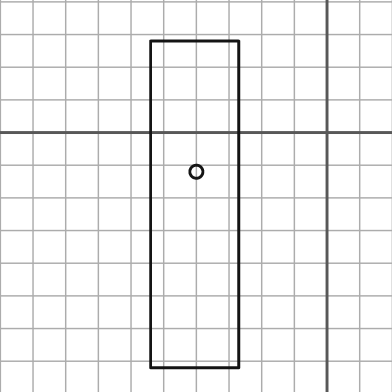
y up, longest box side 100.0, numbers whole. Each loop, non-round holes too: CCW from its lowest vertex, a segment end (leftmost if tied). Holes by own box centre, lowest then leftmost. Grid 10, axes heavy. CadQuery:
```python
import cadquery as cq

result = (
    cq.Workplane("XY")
    .moveTo(-54.0, -72.0)
    .lineTo(-27.0, -72.0)
    .lineTo(-27.0, 28.0)
    .lineTo(-54.0, 28.0)
    .close()
    .moveTo(-40.0, -12.0)
    .circle(2.0)
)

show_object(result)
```